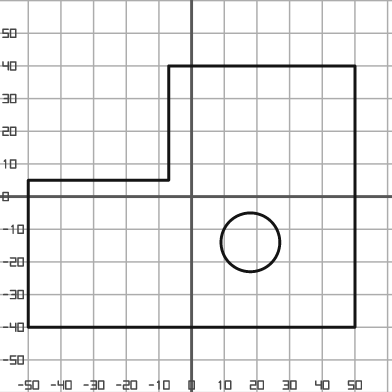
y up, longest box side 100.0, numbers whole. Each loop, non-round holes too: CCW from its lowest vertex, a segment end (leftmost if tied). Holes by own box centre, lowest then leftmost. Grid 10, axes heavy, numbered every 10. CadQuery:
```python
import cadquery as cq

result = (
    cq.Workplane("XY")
    .moveTo(-50.0, -40.0)
    .lineTo(50.0, -40.0)
    .lineTo(50.0, 40.0)
    .lineTo(-7.0, 40.0)
    .lineTo(-7.0, 5.0)
    .lineTo(-50.0, 5.0)
    .close()
    .moveTo(18.0, -14.0)
    .circle(9.0)
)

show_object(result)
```